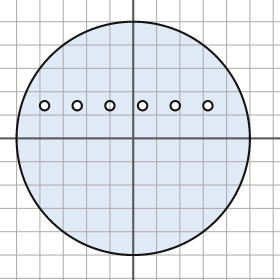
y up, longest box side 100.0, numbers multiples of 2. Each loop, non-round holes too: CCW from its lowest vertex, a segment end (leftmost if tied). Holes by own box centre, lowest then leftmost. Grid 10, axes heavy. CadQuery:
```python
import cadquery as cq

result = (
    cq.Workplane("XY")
    .moveTo(0.0, 0.0)
    .circle(50.0)
    .moveTo(-38.0, 14.0)
    .circle(2.0)
    .moveTo(-24.0, 14.0)
    .circle(2.0)
    .moveTo(-10.0, 14.0)
    .circle(2.0)
    .moveTo(4.0, 14.0)
    .circle(2.0)
    .moveTo(18.0, 14.0)
    .circle(2.0)
    .moveTo(32.0, 14.0)
    .circle(2.0)
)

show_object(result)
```